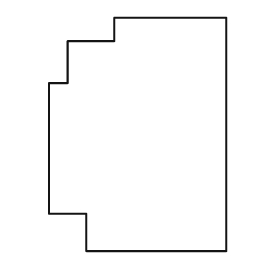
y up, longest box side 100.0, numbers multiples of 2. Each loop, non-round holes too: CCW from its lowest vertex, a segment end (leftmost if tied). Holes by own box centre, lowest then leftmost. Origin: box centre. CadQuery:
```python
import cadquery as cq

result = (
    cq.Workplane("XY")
    .moveTo(-22.0, -50.0)
    .lineTo(38.0, -50.0)
    .lineTo(38.0, 50.0)
    .lineTo(-10.0, 50.0)
    .lineTo(-10.0, 40.0)
    .lineTo(-30.0, 40.0)
    .lineTo(-30.0, 22.0)
    .lineTo(-38.0, 22.0)
    .lineTo(-38.0, -34.0)
    .lineTo(-22.0, -34.0)
    .close()
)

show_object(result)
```